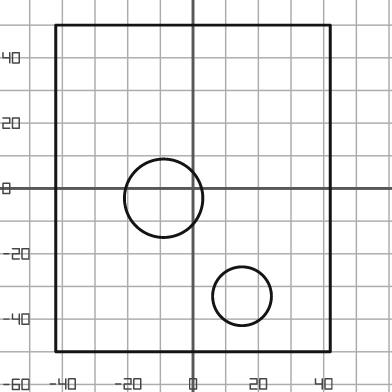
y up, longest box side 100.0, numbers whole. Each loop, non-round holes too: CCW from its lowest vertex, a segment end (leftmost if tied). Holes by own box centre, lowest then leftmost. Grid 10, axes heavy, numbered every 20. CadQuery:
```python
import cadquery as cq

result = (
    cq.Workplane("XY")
    .moveTo(-42.0, -50.0)
    .lineTo(42.0, -50.0)
    .lineTo(42.0, 50.0)
    .lineTo(-42.0, 50.0)
    .close()
    .moveTo(15.0, -33.0)
    .circle(9.0)
    .moveTo(-9.0, -3.0)
    .circle(12.0)
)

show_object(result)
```